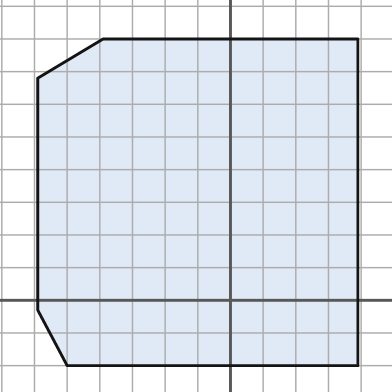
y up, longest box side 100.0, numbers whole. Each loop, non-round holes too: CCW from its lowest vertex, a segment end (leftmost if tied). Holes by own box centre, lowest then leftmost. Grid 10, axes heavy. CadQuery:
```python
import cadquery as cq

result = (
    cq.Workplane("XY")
    .moveTo(-50.0, -20.0)
    .lineTo(39.0, -20.0)
    .lineTo(39.0, 80.0)
    .lineTo(-39.0, 80.0)
    .lineTo(-59.0, 68.0)
    .lineTo(-59.0, -3.0)
    .close()
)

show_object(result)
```